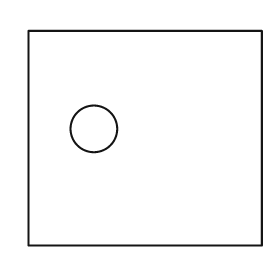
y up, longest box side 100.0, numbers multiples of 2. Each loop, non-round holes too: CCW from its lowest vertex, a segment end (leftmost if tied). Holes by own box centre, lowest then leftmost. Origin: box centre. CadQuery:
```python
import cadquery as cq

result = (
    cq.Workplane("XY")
    .moveTo(-50.0, -46.0)
    .lineTo(50.0, -46.0)
    .lineTo(50.0, 46.0)
    .lineTo(-50.0, 46.0)
    .close()
    .moveTo(-22.0, 4.0)
    .circle(10.0)
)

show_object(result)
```